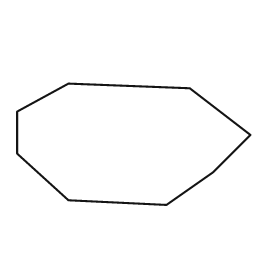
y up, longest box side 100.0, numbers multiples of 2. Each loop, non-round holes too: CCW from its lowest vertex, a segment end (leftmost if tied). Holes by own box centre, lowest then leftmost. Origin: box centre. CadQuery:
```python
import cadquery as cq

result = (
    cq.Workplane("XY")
    .moveTo(14.0, -26.0)
    .lineTo(34.0, -12.0)
    .lineTo(50.0, 4.0)
    .lineTo(24.0, 24.0)
    .lineTo(-28.0, 26.0)
    .lineTo(-50.0, 14.0)
    .lineTo(-50.0, -4.0)
    .lineTo(-28.0, -24.0)
    .close()
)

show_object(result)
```